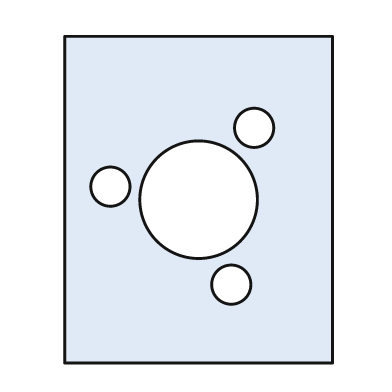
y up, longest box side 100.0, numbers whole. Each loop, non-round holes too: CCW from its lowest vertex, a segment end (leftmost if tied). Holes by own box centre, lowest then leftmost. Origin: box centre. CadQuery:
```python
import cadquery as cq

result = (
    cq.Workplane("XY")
    .moveTo(-41.0, -50.0)
    .lineTo(41.0, -50.0)
    .lineTo(41.0, 50.0)
    .lineTo(-41.0, 50.0)
    .close()
    .moveTo(10.0, -26.0)
    .circle(6.0)
    .moveTo(0.0, 0.0)
    .circle(18.0)
    .moveTo(-27.0, 4.0)
    .circle(6.0)
    .moveTo(17.0, 22.0)
    .circle(6.0)
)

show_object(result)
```